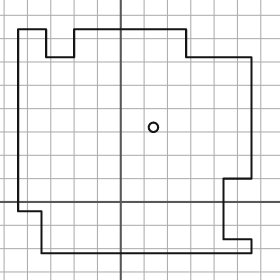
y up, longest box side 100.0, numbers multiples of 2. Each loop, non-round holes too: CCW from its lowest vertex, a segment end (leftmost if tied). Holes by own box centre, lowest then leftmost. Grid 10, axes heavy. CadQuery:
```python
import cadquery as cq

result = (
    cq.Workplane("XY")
    .moveTo(-34.0, -22.0)
    .lineTo(56.0, -22.0)
    .lineTo(56.0, -16.0)
    .lineTo(44.0, -16.0)
    .lineTo(44.0, 10.0)
    .lineTo(56.0, 10.0)
    .lineTo(56.0, 62.0)
    .lineTo(28.0, 62.0)
    .lineTo(28.0, 74.0)
    .lineTo(-20.0, 74.0)
    .lineTo(-20.0, 62.0)
    .lineTo(-32.0, 62.0)
    .lineTo(-32.0, 74.0)
    .lineTo(-44.0, 74.0)
    .lineTo(-44.0, -4.0)
    .lineTo(-34.0, -4.0)
    .close()
    .moveTo(14.0, 32.0)
    .circle(2.0)
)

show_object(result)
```